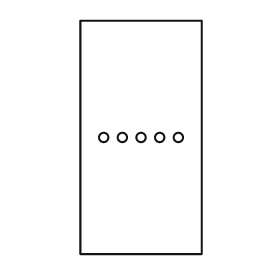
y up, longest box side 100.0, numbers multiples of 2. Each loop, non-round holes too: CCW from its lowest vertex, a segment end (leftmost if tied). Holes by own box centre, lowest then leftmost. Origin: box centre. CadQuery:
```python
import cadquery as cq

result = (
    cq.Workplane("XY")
    .moveTo(-26.0, -50.0)
    .lineTo(26.0, -50.0)
    .lineTo(26.0, 50.0)
    .lineTo(-26.0, 50.0)
    .close()
    .moveTo(-16.0, 0.0)
    .circle(2.0)
    .moveTo(-8.0, 0.0)
    .circle(2.0)
    .moveTo(0.0, 0.0)
    .circle(2.0)
    .moveTo(8.0, 0.0)
    .circle(2.0)
    .moveTo(16.0, 0.0)
    .circle(2.0)
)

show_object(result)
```